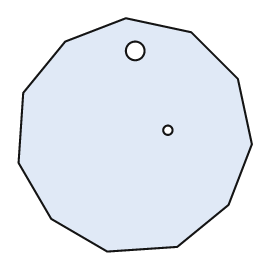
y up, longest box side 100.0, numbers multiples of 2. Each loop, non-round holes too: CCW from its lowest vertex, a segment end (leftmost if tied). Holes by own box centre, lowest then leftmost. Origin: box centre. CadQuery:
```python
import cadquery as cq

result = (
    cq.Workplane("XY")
    .moveTo(-12.0, -50.0)
    .lineTo(18.0, -48.0)
    .lineTo(40.0, -30.0)
    .lineTo(50.0, -4.0)
    .lineTo(44.0, 24.0)
    .lineTo(24.0, 44.0)
    .lineTo(-4.0, 50.0)
    .lineTo(-30.0, 40.0)
    .lineTo(-48.0, 18.0)
    .lineTo(-50.0, -12.0)
    .lineTo(-36.0, -36.0)
    .close()
    .moveTo(14.0, 2.0)
    .circle(2.0)
    .moveTo(0.0, 36.0)
    .circle(4.0)
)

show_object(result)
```